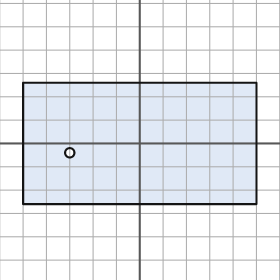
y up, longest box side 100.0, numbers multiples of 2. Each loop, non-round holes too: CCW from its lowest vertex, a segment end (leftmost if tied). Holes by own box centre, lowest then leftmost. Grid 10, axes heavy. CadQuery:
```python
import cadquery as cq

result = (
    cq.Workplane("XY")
    .moveTo(-50.0, -26.0)
    .lineTo(50.0, -26.0)
    .lineTo(50.0, 26.0)
    .lineTo(-50.0, 26.0)
    .close()
    .moveTo(-30.0, -4.0)
    .circle(2.0)
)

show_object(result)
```